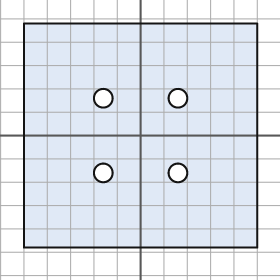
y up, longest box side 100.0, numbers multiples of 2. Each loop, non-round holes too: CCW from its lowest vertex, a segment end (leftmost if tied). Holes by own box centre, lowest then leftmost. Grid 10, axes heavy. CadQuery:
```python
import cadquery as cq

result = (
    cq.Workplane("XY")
    .moveTo(-50.0, -48.0)
    .lineTo(50.0, -48.0)
    .lineTo(50.0, 48.0)
    .lineTo(-50.0, 48.0)
    .close()
    .moveTo(-16.0, -16.0)
    .circle(4.0)
    .moveTo(16.0, -16.0)
    .circle(4.0)
    .moveTo(-16.0, 16.0)
    .circle(4.0)
    .moveTo(16.0, 16.0)
    .circle(4.0)
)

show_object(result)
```